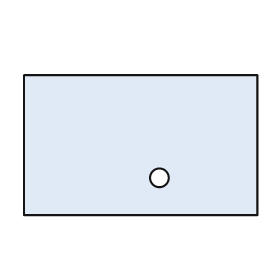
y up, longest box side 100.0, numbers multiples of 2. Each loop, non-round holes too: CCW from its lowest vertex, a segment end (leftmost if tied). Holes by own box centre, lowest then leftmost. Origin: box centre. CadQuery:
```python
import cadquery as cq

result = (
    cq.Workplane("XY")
    .moveTo(-50.0, -30.0)
    .lineTo(50.0, -30.0)
    .lineTo(50.0, 30.0)
    .lineTo(-50.0, 30.0)
    .close()
    .moveTo(8.0, -14.0)
    .circle(4.0)
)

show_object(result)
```